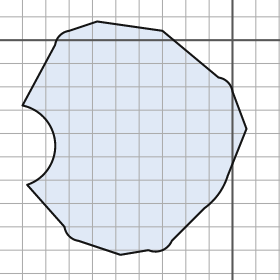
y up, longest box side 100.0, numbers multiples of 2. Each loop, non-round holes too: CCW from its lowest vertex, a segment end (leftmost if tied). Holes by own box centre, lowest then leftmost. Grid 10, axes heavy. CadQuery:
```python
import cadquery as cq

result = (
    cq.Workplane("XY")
    .moveTo(-48.0, -92.0)
    .lineTo(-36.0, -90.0)
    .threePointArc((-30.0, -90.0), (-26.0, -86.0))
    .lineTo(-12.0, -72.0)
    .threePointArc((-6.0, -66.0), (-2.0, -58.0))
    .lineTo(6.0, -38.0)
    .lineTo(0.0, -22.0)
    .threePointArc((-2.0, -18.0), (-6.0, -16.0))
    .lineTo(-30.0, 4.0)
    .lineTo(-58.0, 8.0)
    .lineTo(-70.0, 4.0)
    .threePointArc((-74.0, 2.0), (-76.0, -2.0))
    .lineTo(-90.0, -28.0)
    .threePointArc((-76.0, -44.0), (-88.0, -62.0))
    .lineTo(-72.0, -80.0)
    .threePointArc((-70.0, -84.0), (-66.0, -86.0))
    .close()
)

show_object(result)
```